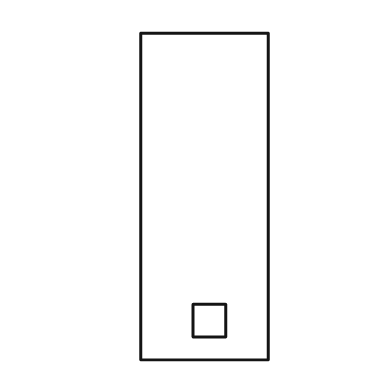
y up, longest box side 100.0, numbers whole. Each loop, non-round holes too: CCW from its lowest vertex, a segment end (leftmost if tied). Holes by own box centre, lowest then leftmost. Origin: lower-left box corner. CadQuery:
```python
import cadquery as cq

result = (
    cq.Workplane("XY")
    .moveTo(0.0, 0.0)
    .lineTo(39.0, 0.0)
    .lineTo(39.0, 100.0)
    .lineTo(0.0, 100.0)
    .close()
    .moveTo(16.0, 7.0)
    .lineTo(26.0, 7.0)
    .lineTo(26.0, 17.0)
    .lineTo(16.0, 17.0)
    .close()
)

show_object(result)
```